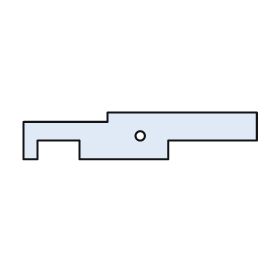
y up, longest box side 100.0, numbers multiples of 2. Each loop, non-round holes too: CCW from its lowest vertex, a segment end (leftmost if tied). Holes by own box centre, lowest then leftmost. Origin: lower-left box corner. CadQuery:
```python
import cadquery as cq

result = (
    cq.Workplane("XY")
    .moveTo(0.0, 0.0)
    .lineTo(6.0, 0.0)
    .lineTo(6.0, 8.0)
    .lineTo(24.0, 8.0)
    .lineTo(24.0, 0.0)
    .lineTo(62.0, 0.0)
    .lineTo(62.0, 8.0)
    .lineTo(100.0, 8.0)
    .lineTo(100.0, 20.0)
    .lineTo(36.0, 20.0)
    .lineTo(36.0, 16.0)
    .lineTo(0.0, 16.0)
    .close()
    .moveTo(50.0, 10.0)
    .circle(2.0)
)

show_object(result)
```